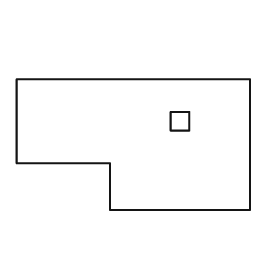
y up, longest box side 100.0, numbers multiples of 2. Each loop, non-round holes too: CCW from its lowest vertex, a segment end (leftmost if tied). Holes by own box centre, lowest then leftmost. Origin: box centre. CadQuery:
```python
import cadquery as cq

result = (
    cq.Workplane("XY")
    .moveTo(-10.0, -28.0)
    .lineTo(50.0, -28.0)
    .lineTo(50.0, 28.0)
    .lineTo(-50.0, 28.0)
    .lineTo(-50.0, -8.0)
    .lineTo(-10.0, -8.0)
    .close()
    .moveTo(16.0, 6.0)
    .lineTo(24.0, 6.0)
    .lineTo(24.0, 14.0)
    .lineTo(16.0, 14.0)
    .close()
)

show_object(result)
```